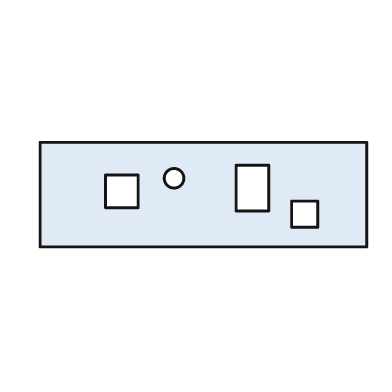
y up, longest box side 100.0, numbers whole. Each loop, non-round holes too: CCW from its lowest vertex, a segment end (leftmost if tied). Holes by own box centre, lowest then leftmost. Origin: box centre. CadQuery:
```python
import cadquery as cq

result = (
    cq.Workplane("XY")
    .moveTo(-50.0, -16.0)
    .lineTo(50.0, -16.0)
    .lineTo(50.0, 16.0)
    .lineTo(-50.0, 16.0)
    .close()
    .moveTo(27.0, -10.0)
    .lineTo(35.0, -10.0)
    .lineTo(35.0, -2.0)
    .lineTo(27.0, -2.0)
    .close()
    .moveTo(-30.0, -4.0)
    .lineTo(-20.0, -4.0)
    .lineTo(-20.0, 6.0)
    .lineTo(-30.0, 6.0)
    .close()
    .moveTo(10.0, -5.0)
    .lineTo(20.0, -5.0)
    .lineTo(20.0, 9.0)
    .lineTo(10.0, 9.0)
    .close()
    .moveTo(-9.0, 5.0)
    .circle(3.0)
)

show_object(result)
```